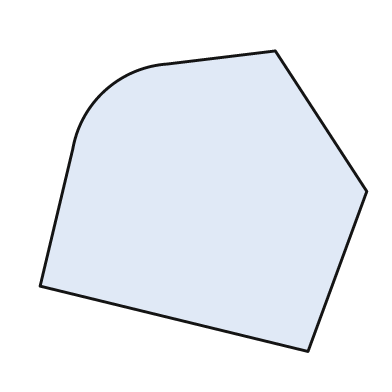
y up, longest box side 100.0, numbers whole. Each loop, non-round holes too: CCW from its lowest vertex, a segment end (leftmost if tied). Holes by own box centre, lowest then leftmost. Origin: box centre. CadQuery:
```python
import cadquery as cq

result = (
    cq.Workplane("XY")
    .moveTo(32.0, -46.0)
    .lineTo(50.0, 3.0)
    .lineTo(22.0, 46.0)
    .lineTo(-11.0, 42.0)
    .threePointArc((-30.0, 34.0), (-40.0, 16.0))
    .lineTo(-50.0, -26.0)
    .close()
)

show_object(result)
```